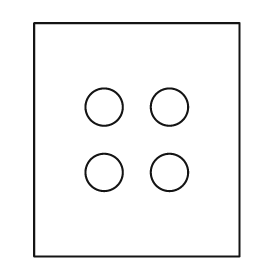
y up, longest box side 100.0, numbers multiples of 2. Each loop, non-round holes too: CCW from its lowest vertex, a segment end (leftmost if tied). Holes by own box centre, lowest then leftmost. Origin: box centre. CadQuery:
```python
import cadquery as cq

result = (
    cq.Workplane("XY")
    .moveTo(-44.0, -50.0)
    .lineTo(44.0, -50.0)
    .lineTo(44.0, 50.0)
    .lineTo(-44.0, 50.0)
    .close()
    .moveTo(-14.0, -14.0)
    .circle(8.0)
    .moveTo(14.0, -14.0)
    .circle(8.0)
    .moveTo(-14.0, 14.0)
    .circle(8.0)
    .moveTo(14.0, 14.0)
    .circle(8.0)
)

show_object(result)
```